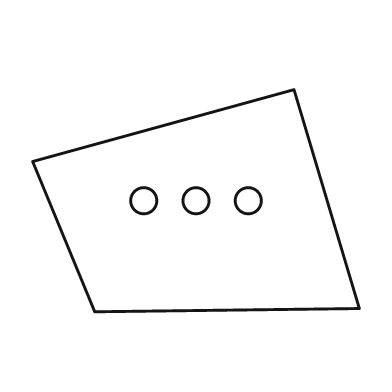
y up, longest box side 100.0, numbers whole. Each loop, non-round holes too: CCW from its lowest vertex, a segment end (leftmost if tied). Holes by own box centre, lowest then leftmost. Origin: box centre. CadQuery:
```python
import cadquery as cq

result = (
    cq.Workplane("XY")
    .moveTo(-31.0, -34.0)
    .lineTo(50.0, -33.0)
    .lineTo(30.0, 34.0)
    .lineTo(-50.0, 12.0)
    .close()
    .moveTo(-16.0, 0.0)
    .circle(4.0)
    .moveTo(0.0, 0.0)
    .circle(4.0)
    .moveTo(16.0, 0.0)
    .circle(4.0)
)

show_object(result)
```